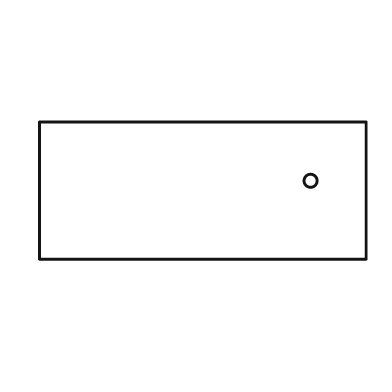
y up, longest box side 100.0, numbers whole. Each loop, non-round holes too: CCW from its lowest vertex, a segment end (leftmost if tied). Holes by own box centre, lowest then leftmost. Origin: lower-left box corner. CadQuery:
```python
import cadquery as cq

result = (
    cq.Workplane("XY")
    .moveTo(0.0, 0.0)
    .lineTo(100.0, 0.0)
    .lineTo(100.0, 42.0)
    .lineTo(0.0, 42.0)
    .close()
    .moveTo(83.0, 24.0)
    .circle(2.0)
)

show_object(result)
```